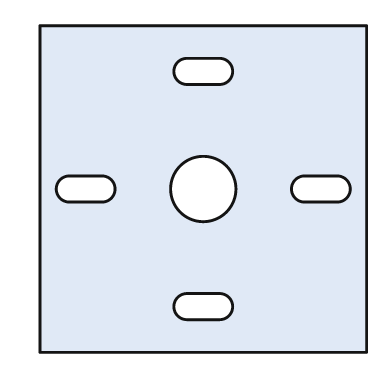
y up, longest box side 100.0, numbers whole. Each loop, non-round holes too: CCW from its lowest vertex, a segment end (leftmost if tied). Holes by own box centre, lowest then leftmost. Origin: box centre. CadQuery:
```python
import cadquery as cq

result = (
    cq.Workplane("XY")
    .moveTo(-50.0, -50.0)
    .lineTo(50.0, -50.0)
    .lineTo(50.0, 50.0)
    .lineTo(-50.0, 50.0)
    .close()
    .moveTo(-5.0, -40.0)
    .lineTo(5.0, -40.0)
    .threePointArc((9.0, -36.0), (5.0, -32.0))
    .lineTo(-5.0, -32.0)
    .threePointArc((-9.0, -36.0), (-5.0, -40.0))
    .close()
    .moveTo(-41.0, -4.0)
    .lineTo(-31.0, -4.0)
    .threePointArc((-27.0, 0.0), (-31.0, 4.0))
    .lineTo(-41.0, 4.0)
    .threePointArc((-45.0, 0.0), (-41.0, -4.0))
    .close()
    .moveTo(0.0, 0.0)
    .circle(10.0)
    .moveTo(31.0, -4.0)
    .lineTo(41.0, -4.0)
    .threePointArc((45.0, 0.0), (41.0, 4.0))
    .lineTo(31.0, 4.0)
    .threePointArc((27.0, 0.0), (31.0, -4.0))
    .close()
    .moveTo(-5.0, 32.0)
    .lineTo(5.0, 32.0)
    .threePointArc((9.0, 36.0), (5.0, 40.0))
    .lineTo(-5.0, 40.0)
    .threePointArc((-9.0, 36.0), (-5.0, 32.0))
    .close()
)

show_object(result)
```